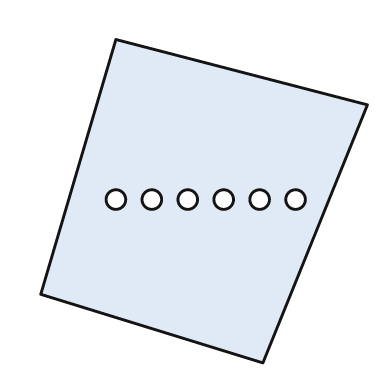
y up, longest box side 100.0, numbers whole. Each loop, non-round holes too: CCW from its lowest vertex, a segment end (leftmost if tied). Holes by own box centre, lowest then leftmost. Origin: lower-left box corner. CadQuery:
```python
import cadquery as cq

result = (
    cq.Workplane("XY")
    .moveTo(68.0, 0.0)
    .lineTo(100.0, 79.0)
    .lineTo(23.0, 99.0)
    .lineTo(0.0, 21.0)
    .close()
    .moveTo(23.0, 50.0)
    .circle(3.0)
    .moveTo(34.0, 50.0)
    .circle(3.0)
    .moveTo(45.0, 50.0)
    .circle(3.0)
    .moveTo(56.0, 50.0)
    .circle(3.0)
    .moveTo(67.0, 50.0)
    .circle(3.0)
    .moveTo(78.0, 50.0)
    .circle(3.0)
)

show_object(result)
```